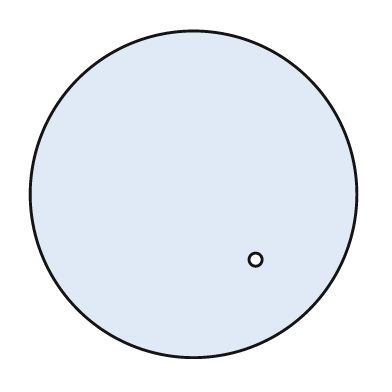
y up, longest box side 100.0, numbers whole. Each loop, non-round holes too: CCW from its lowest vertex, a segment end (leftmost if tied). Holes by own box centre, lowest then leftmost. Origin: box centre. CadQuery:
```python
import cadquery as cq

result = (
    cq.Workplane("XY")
    .moveTo(0.0, 0.0)
    .circle(50.0)
    .moveTo(19.0, -20.0)
    .circle(2.0)
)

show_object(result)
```